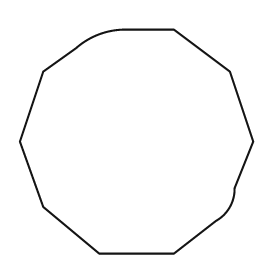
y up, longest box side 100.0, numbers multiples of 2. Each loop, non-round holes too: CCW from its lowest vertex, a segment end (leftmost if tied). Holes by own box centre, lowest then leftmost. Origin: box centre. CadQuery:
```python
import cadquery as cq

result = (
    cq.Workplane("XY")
    .moveTo(-16.0, -48.0)
    .lineTo(16.0, -48.0)
    .lineTo(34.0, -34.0)
    .threePointArc((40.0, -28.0), (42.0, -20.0))
    .lineTo(50.0, 0.0)
    .lineTo(40.0, 30.0)
    .lineTo(16.0, 48.0)
    .lineTo(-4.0, 48.0)
    .threePointArc((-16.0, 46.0), (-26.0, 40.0))
    .lineTo(-40.0, 30.0)
    .lineTo(-50.0, 0.0)
    .lineTo(-40.0, -28.0)
    .close()
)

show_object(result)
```